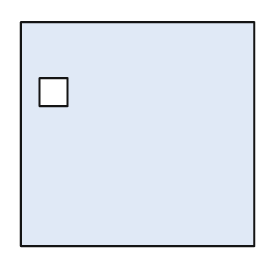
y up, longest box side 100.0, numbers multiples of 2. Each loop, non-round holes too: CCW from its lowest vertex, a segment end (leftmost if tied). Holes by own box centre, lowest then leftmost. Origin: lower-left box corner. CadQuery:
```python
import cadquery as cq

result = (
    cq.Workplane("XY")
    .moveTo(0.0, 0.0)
    .lineTo(100.0, 0.0)
    .lineTo(100.0, 96.0)
    .lineTo(0.0, 96.0)
    .close()
    .moveTo(8.0, 60.0)
    .lineTo(20.0, 60.0)
    .lineTo(20.0, 72.0)
    .lineTo(8.0, 72.0)
    .close()
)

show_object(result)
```